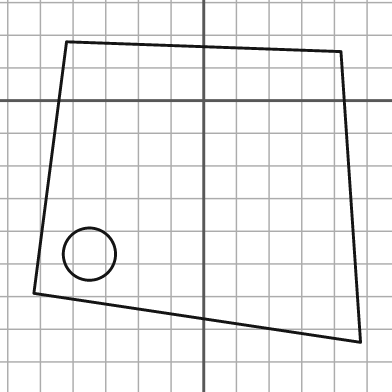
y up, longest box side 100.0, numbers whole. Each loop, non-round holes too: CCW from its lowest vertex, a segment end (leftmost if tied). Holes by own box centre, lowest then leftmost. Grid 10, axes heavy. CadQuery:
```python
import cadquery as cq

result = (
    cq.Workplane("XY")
    .moveTo(48.0, -74.0)
    .lineTo(42.0, 15.0)
    .lineTo(-42.0, 18.0)
    .lineTo(-52.0, -59.0)
    .close()
    .moveTo(-35.0, -47.0)
    .circle(8.0)
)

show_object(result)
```